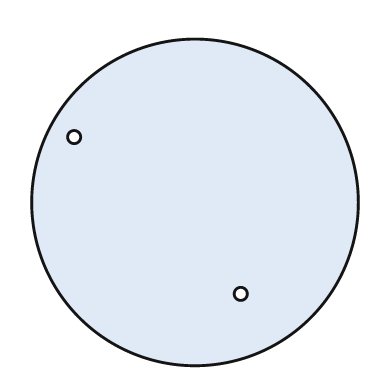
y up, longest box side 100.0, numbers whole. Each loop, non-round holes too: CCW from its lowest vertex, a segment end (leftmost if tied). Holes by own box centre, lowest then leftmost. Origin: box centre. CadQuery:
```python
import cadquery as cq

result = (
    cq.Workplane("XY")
    .moveTo(0.0, 0.0)
    .circle(50.0)
    .moveTo(14.0, -28.0)
    .circle(2.0)
    .moveTo(-37.0, 20.0)
    .circle(2.0)
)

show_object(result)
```